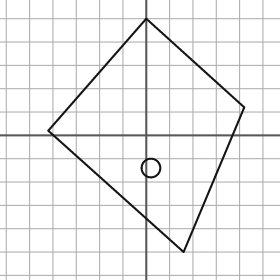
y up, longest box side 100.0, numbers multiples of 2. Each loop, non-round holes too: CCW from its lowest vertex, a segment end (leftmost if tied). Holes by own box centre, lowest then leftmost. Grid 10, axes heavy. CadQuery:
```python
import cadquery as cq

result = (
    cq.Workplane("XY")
    .moveTo(16.0, -50.0)
    .lineTo(42.0, 12.0)
    .lineTo(0.0, 50.0)
    .lineTo(-42.0, 2.0)
    .close()
    .moveTo(2.0, -14.0)
    .circle(4.0)
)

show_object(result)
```